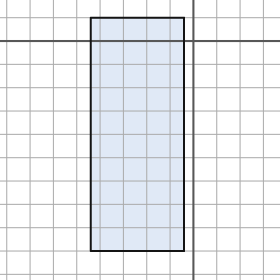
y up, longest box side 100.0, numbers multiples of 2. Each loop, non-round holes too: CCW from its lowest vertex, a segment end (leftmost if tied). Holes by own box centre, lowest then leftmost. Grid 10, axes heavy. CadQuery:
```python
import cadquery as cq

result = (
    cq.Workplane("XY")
    .moveTo(-44.0, -90.0)
    .lineTo(-4.0, -90.0)
    .lineTo(-4.0, 10.0)
    .lineTo(-44.0, 10.0)
    .close()
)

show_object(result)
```